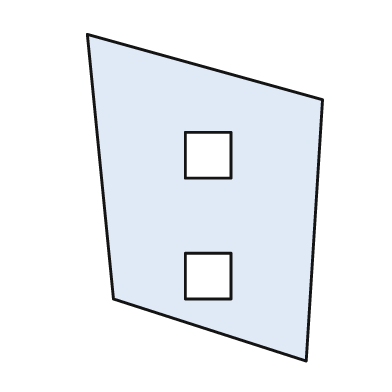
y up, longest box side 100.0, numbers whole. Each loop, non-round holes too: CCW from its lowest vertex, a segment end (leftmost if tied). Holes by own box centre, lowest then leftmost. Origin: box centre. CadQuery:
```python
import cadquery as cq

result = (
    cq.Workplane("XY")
    .moveTo(31.0, -50.0)
    .lineTo(36.0, 30.0)
    .lineTo(-36.0, 50.0)
    .lineTo(-28.0, -31.0)
    .close()
    .moveTo(-6.0, -31.0)
    .lineTo(8.0, -31.0)
    .lineTo(8.0, -17.0)
    .lineTo(-6.0, -17.0)
    .close()
    .moveTo(-6.0, 6.0)
    .lineTo(8.0, 6.0)
    .lineTo(8.0, 20.0)
    .lineTo(-6.0, 20.0)
    .close()
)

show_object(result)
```